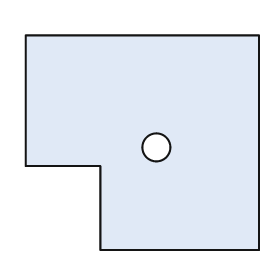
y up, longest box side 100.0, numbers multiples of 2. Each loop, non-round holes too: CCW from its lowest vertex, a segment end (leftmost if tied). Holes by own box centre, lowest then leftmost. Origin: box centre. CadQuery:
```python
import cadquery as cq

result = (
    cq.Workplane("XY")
    .moveTo(-18.0, -46.0)
    .lineTo(50.0, -46.0)
    .lineTo(50.0, 46.0)
    .lineTo(-50.0, 46.0)
    .lineTo(-50.0, -10.0)
    .lineTo(-18.0, -10.0)
    .close()
    .moveTo(6.0, -2.0)
    .circle(6.0)
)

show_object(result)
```